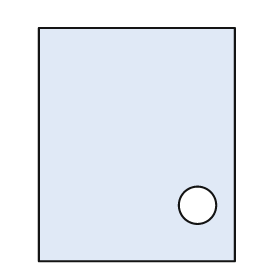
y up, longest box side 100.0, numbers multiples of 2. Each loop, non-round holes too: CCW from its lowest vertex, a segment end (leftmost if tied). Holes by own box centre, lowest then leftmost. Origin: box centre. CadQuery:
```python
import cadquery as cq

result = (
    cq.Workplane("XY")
    .moveTo(-42.0, -50.0)
    .lineTo(42.0, -50.0)
    .lineTo(42.0, 50.0)
    .lineTo(-42.0, 50.0)
    .close()
    .moveTo(26.0, -26.0)
    .circle(8.0)
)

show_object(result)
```